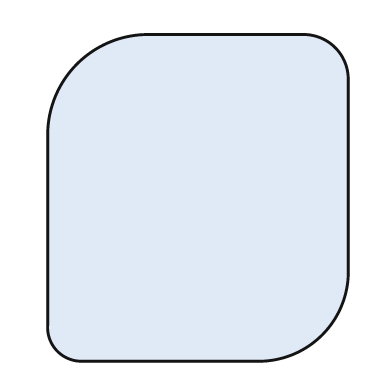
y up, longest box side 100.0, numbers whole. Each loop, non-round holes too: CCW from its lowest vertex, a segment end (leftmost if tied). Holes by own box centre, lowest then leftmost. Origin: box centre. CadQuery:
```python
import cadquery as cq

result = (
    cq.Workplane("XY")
    .moveTo(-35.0, -50.0)
    .lineTo(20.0, -50.0)
    .threePointArc((38.0, -42.0), (46.0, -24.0))
    .lineTo(46.0, 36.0)
    .threePointArc((42.0, 46.0), (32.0, 50.0))
    .lineTo(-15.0, 50.0)
    .threePointArc((-37.0, 41.0), (-46.0, 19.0))
    .lineTo(-46.0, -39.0)
    .threePointArc((-43.0, -47.0), (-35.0, -50.0))
    .close()
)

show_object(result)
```